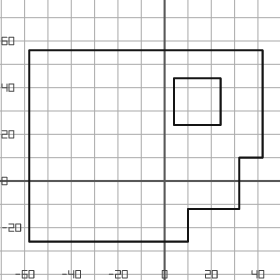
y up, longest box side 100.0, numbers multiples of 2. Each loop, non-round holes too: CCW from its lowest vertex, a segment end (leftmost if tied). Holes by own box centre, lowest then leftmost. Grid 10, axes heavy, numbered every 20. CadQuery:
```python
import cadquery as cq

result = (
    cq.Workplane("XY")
    .moveTo(-58.0, -26.0)
    .lineTo(10.0, -26.0)
    .lineTo(10.0, -12.0)
    .lineTo(32.0, -12.0)
    .lineTo(32.0, 10.0)
    .lineTo(42.0, 10.0)
    .lineTo(42.0, 56.0)
    .lineTo(-58.0, 56.0)
    .close()
    .moveTo(4.0, 24.0)
    .lineTo(24.0, 24.0)
    .lineTo(24.0, 44.0)
    .lineTo(4.0, 44.0)
    .close()
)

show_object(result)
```